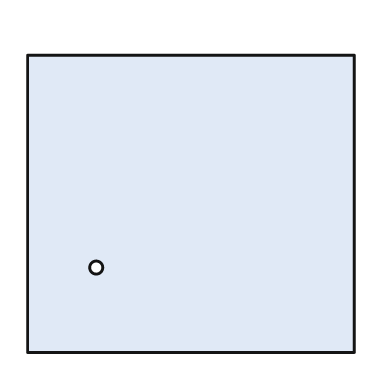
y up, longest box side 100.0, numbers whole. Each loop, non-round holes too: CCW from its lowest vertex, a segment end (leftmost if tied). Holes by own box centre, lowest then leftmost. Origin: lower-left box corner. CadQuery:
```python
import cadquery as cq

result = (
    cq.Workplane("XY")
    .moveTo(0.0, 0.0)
    .lineTo(100.0, 0.0)
    .lineTo(100.0, 91.0)
    .lineTo(0.0, 91.0)
    .close()
    .moveTo(21.0, 26.0)
    .circle(2.0)
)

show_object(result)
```